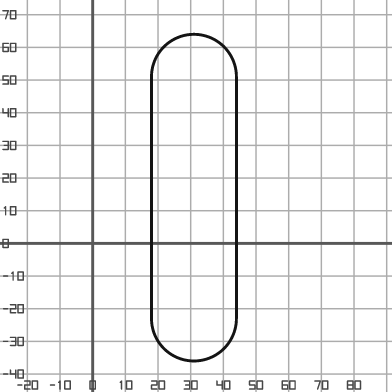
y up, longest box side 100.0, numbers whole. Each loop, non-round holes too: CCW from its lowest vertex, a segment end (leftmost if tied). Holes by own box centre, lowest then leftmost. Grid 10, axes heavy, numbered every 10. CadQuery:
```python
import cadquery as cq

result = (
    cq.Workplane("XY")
    .moveTo(18.0, -23.0)
    .threePointArc((31.0, -36.0), (44.0, -23.0))
    .lineTo(44.0, 51.0)
    .threePointArc((31.0, 64.0), (18.0, 51.0))
    .close()
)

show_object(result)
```